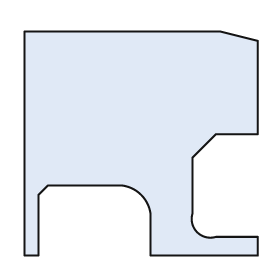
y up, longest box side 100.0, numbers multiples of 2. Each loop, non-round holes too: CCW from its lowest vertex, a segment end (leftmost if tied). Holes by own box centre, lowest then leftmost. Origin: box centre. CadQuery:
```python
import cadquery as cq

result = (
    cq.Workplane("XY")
    .moveTo(-50.0, -48.0)
    .lineTo(-44.0, -48.0)
    .lineTo(-44.0, -22.0)
    .lineTo(-40.0, -18.0)
    .lineTo(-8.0, -18.0)
    .threePointArc((0.0, -22.0), (4.0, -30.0))
    .lineTo(4.0, -48.0)
    .lineTo(50.0, -48.0)
    .lineTo(50.0, -40.0)
    .lineTo(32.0, -40.0)
    .threePointArc((24.0, -38.0), (22.0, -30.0))
    .lineTo(22.0, -6.0)
    .lineTo(32.0, 4.0)
    .lineTo(50.0, 4.0)
    .lineTo(50.0, 44.0)
    .lineTo(34.0, 48.0)
    .lineTo(-50.0, 48.0)
    .close()
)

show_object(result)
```